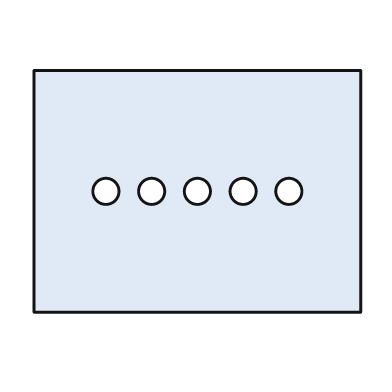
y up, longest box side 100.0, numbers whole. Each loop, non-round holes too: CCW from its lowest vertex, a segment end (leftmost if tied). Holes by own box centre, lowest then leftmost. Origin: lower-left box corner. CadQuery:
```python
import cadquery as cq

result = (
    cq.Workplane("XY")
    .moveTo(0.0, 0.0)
    .lineTo(100.0, 0.0)
    .lineTo(100.0, 74.0)
    .lineTo(0.0, 74.0)
    .close()
    .moveTo(22.0, 37.0)
    .circle(4.0)
    .moveTo(36.0, 37.0)
    .circle(4.0)
    .moveTo(50.0, 37.0)
    .circle(4.0)
    .moveTo(64.0, 37.0)
    .circle(4.0)
    .moveTo(78.0, 37.0)
    .circle(4.0)
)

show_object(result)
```